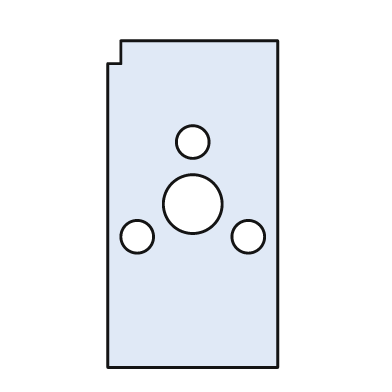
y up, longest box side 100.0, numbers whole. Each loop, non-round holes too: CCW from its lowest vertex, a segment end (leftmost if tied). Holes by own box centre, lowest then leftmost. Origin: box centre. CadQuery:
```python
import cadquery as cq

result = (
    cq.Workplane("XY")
    .moveTo(-26.0, -50.0)
    .lineTo(26.0, -50.0)
    .lineTo(26.0, 50.0)
    .lineTo(-22.0, 50.0)
    .lineTo(-22.0, 43.0)
    .lineTo(-26.0, 43.0)
    .close()
    .moveTo(-17.0, -10.0)
    .circle(5.0)
    .moveTo(17.0, -10.0)
    .circle(5.0)
    .moveTo(0.0, 0.0)
    .circle(9.0)
    .moveTo(0.0, 19.0)
    .circle(5.0)
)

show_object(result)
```